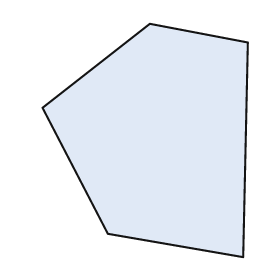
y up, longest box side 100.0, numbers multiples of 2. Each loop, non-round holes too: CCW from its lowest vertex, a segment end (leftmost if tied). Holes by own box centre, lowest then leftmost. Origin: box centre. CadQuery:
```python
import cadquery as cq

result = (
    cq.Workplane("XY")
    .moveTo(42.0, -50.0)
    .lineTo(44.0, 42.0)
    .lineTo(2.0, 50.0)
    .lineTo(-44.0, 14.0)
    .lineTo(-16.0, -40.0)
    .close()
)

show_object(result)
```